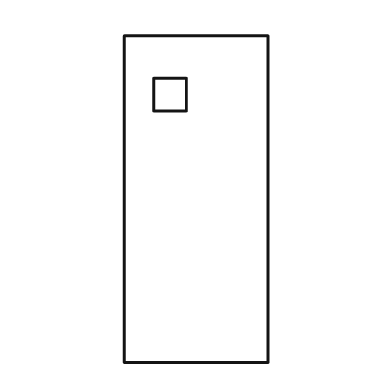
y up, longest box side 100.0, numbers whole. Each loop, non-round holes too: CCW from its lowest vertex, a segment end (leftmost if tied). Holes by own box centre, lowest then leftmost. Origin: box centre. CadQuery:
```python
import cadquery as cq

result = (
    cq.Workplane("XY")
    .moveTo(-22.0, -50.0)
    .lineTo(22.0, -50.0)
    .lineTo(22.0, 50.0)
    .lineTo(-22.0, 50.0)
    .close()
    .moveTo(-13.0, 27.0)
    .lineTo(-3.0, 27.0)
    .lineTo(-3.0, 37.0)
    .lineTo(-13.0, 37.0)
    .close()
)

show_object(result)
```